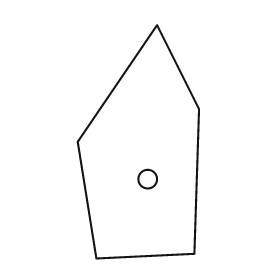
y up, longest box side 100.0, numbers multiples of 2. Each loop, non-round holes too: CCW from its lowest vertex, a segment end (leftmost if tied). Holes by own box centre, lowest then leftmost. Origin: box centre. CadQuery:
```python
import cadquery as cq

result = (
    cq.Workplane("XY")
    .moveTo(-18.0, -50.0)
    .lineTo(24.0, -48.0)
    .lineTo(26.0, 14.0)
    .lineTo(8.0, 50.0)
    .lineTo(-26.0, 0.0)
    .close()
    .moveTo(4.0, -16.0)
    .circle(4.0)
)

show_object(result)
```